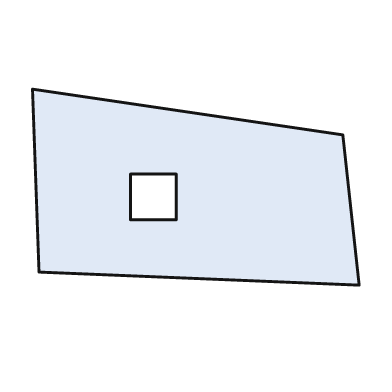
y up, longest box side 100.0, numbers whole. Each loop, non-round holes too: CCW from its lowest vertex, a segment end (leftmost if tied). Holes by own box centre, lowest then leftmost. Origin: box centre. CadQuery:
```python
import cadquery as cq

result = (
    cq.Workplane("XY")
    .moveTo(50.0, -30.0)
    .lineTo(45.0, 16.0)
    .lineTo(-50.0, 30.0)
    .lineTo(-48.0, -26.0)
    .close()
    .moveTo(-20.0, -10.0)
    .lineTo(-6.0, -10.0)
    .lineTo(-6.0, 4.0)
    .lineTo(-20.0, 4.0)
    .close()
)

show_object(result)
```